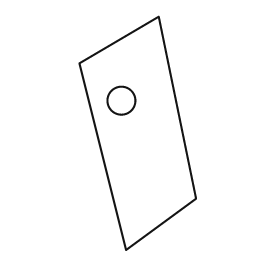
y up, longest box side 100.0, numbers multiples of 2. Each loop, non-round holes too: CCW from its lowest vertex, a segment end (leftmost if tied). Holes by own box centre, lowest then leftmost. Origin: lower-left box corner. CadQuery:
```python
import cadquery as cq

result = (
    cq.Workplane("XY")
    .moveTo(20.0, 0.0)
    .lineTo(50.0, 22.0)
    .lineTo(34.0, 100.0)
    .lineTo(0.0, 80.0)
    .close()
    .moveTo(18.0, 64.0)
    .circle(6.0)
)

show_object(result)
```